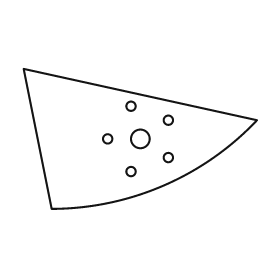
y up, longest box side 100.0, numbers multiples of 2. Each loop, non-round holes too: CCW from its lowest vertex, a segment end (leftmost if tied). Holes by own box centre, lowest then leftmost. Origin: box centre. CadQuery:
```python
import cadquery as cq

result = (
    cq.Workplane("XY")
    .moveTo(-38.0, -30.0)
    .threePointArc((10.0, -20.0), (50.0, 8.0))
    .lineTo(-50.0, 30.0)
    .close()
    .moveTo(-4.0, -14.0)
    .circle(2.0)
    .moveTo(12.0, -8.0)
    .circle(2.0)
    .moveTo(-14.0, 0.0)
    .circle(2.0)
    .moveTo(0.0, 0.0)
    .circle(4.0)
    .moveTo(12.0, 8.0)
    .circle(2.0)
    .moveTo(-4.0, 14.0)
    .circle(2.0)
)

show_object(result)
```